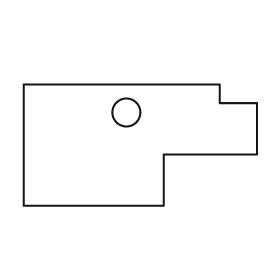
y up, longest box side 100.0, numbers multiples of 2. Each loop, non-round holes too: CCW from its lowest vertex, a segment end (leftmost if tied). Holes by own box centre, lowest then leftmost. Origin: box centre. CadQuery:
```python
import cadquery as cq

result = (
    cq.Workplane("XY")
    .moveTo(-50.0, -26.0)
    .lineTo(10.0, -26.0)
    .lineTo(10.0, -4.0)
    .lineTo(50.0, -4.0)
    .lineTo(50.0, 18.0)
    .lineTo(34.0, 18.0)
    .lineTo(34.0, 26.0)
    .lineTo(-50.0, 26.0)
    .close()
    .moveTo(-6.0, 14.0)
    .circle(6.0)
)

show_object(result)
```